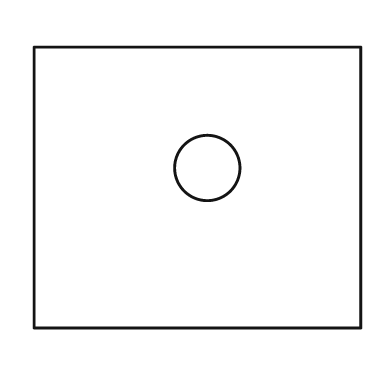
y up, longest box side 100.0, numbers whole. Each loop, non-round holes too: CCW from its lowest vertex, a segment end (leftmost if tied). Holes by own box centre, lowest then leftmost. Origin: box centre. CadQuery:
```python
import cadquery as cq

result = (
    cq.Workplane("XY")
    .moveTo(-50.0, -43.0)
    .lineTo(50.0, -43.0)
    .lineTo(50.0, 43.0)
    .lineTo(-50.0, 43.0)
    .close()
    .moveTo(3.0, 6.0)
    .circle(10.0)
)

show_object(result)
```